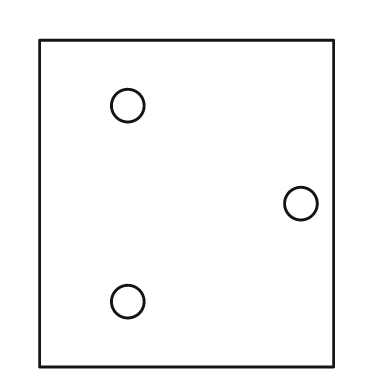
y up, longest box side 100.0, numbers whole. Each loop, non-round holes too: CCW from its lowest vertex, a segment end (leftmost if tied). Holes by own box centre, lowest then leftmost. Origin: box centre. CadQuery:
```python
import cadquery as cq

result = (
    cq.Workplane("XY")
    .moveTo(-45.0, -50.0)
    .lineTo(45.0, -50.0)
    .lineTo(45.0, 50.0)
    .lineTo(-45.0, 50.0)
    .close()
    .moveTo(-18.0, -30.0)
    .circle(5.0)
    .moveTo(35.0, 0.0)
    .circle(5.0)
    .moveTo(-18.0, 30.0)
    .circle(5.0)
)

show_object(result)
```